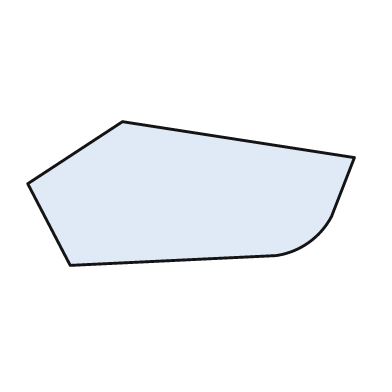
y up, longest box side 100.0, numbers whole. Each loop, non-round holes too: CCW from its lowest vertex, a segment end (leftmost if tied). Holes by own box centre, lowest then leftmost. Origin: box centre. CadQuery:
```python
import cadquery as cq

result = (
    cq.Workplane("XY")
    .moveTo(-37.0, -22.0)
    .lineTo(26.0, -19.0)
    .threePointArc((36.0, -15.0), (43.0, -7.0))
    .lineTo(50.0, 11.0)
    .lineTo(-21.0, 22.0)
    .lineTo(-50.0, 3.0)
    .close()
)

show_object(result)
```